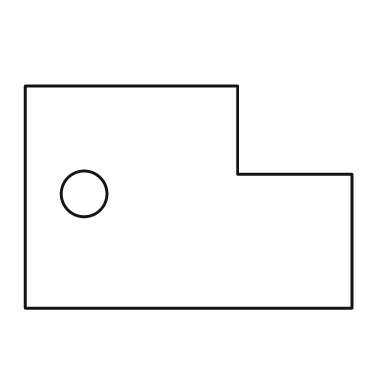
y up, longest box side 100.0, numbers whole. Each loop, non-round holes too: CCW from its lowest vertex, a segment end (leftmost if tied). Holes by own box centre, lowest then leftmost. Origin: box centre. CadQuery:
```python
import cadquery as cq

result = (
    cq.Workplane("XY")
    .moveTo(-50.0, -34.0)
    .lineTo(50.0, -34.0)
    .lineTo(50.0, 7.0)
    .lineTo(15.0, 7.0)
    .lineTo(15.0, 34.0)
    .lineTo(-50.0, 34.0)
    .close()
    .moveTo(-32.0, 1.0)
    .circle(7.0)
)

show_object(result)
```